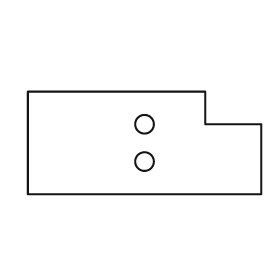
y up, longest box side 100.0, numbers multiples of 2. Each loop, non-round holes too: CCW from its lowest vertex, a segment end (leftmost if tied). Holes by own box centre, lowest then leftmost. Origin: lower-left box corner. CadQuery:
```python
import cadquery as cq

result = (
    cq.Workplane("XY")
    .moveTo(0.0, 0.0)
    .lineTo(100.0, 0.0)
    .lineTo(100.0, 30.0)
    .lineTo(76.0, 30.0)
    .lineTo(76.0, 44.0)
    .lineTo(0.0, 44.0)
    .close()
    .moveTo(50.0, 14.0)
    .circle(4.0)
    .moveTo(50.0, 30.0)
    .circle(4.0)
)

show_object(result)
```